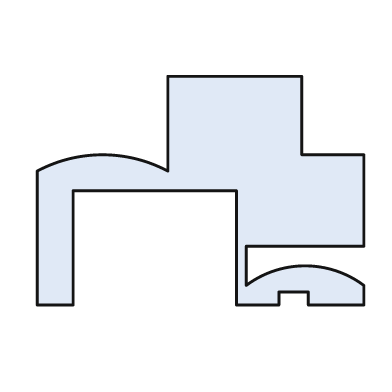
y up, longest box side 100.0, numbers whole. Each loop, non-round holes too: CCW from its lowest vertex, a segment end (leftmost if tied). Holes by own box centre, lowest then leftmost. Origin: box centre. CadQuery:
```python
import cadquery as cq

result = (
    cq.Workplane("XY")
    .moveTo(-50.0, -35.0)
    .lineTo(-39.0, -35.0)
    .lineTo(-39.0, 0.0)
    .lineTo(11.0, 0.0)
    .lineTo(11.0, -35.0)
    .lineTo(24.0, -35.0)
    .lineTo(24.0, -31.0)
    .lineTo(33.0, -31.0)
    .lineTo(33.0, -35.0)
    .lineTo(50.0, -35.0)
    .lineTo(50.0, -29.0)
    .threePointArc((32.0, -23.0), (14.0, -29.0))
    .lineTo(14.0, -17.0)
    .lineTo(50.0, -17.0)
    .lineTo(50.0, 11.0)
    .lineTo(31.0, 11.0)
    .lineTo(31.0, 35.0)
    .lineTo(-10.0, 35.0)
    .lineTo(-10.0, 6.0)
    .threePointArc((-30.0, 11.0), (-50.0, 6.0))
    .close()
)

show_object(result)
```